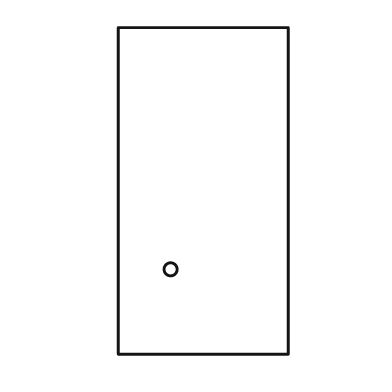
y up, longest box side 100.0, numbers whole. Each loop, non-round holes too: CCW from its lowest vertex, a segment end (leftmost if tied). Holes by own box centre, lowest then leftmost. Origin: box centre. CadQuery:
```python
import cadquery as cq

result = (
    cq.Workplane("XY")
    .moveTo(-26.0, -50.0)
    .lineTo(26.0, -50.0)
    .lineTo(26.0, 50.0)
    .lineTo(-26.0, 50.0)
    .close()
    .moveTo(-10.0, -24.0)
    .circle(2.0)
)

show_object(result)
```